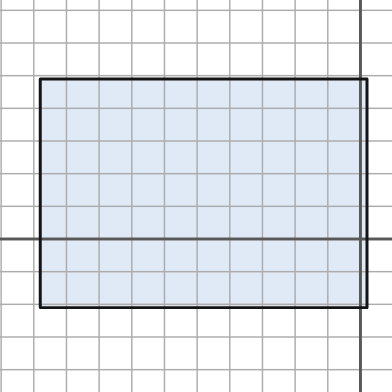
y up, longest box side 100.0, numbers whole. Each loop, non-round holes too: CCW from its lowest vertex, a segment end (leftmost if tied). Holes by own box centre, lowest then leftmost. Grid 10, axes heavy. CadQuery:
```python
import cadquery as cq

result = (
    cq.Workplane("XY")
    .moveTo(-98.0, -21.0)
    .lineTo(2.0, -21.0)
    .lineTo(2.0, 49.0)
    .lineTo(-98.0, 49.0)
    .close()
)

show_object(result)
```